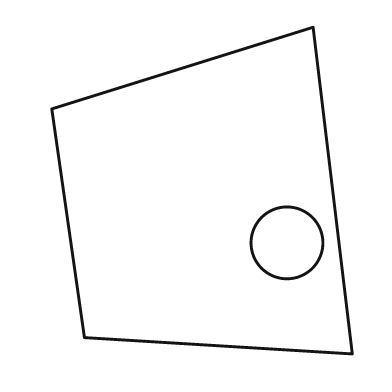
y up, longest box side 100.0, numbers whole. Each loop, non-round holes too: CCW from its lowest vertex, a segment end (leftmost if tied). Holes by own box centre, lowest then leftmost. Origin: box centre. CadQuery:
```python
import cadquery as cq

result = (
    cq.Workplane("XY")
    .moveTo(46.0, -50.0)
    .lineTo(34.0, 50.0)
    .lineTo(-46.0, 25.0)
    .lineTo(-36.0, -45.0)
    .close()
    .moveTo(26.0, -16.0)
    .circle(11.0)
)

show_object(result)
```